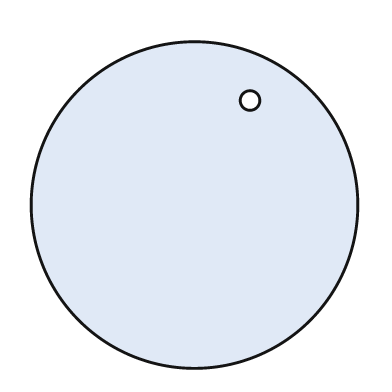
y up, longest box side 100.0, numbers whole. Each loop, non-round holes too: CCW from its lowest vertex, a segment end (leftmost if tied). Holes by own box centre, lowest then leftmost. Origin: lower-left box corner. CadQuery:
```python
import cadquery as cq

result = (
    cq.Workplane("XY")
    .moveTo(50.0, 50.0)
    .circle(50.0)
    .moveTo(67.0, 82.0)
    .circle(3.0)
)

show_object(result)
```